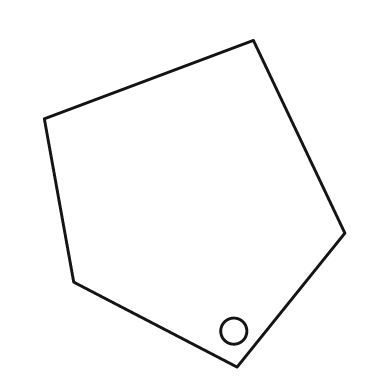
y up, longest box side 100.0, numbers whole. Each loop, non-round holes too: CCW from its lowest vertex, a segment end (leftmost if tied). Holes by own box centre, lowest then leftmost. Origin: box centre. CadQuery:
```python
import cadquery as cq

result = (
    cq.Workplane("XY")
    .moveTo(13.0, -50.0)
    .lineTo(46.0, -9.0)
    .lineTo(18.0, 50.0)
    .lineTo(-46.0, 26.0)
    .lineTo(-37.0, -24.0)
    .close()
    .moveTo(12.0, -39.0)
    .circle(4.0)
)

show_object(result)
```